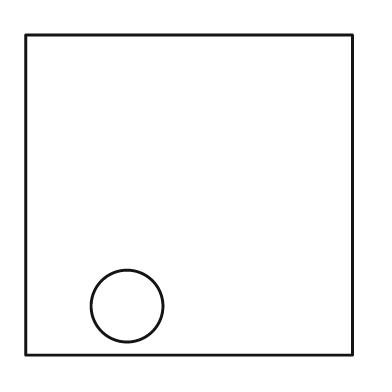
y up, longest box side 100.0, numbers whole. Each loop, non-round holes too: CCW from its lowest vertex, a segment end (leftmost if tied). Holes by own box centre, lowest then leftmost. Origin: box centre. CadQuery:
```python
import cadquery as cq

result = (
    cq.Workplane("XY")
    .moveTo(-50.0, -49.0)
    .lineTo(50.0, -49.0)
    .lineTo(50.0, 49.0)
    .lineTo(-50.0, 49.0)
    .close()
    .moveTo(-19.0, -34.0)
    .circle(11.0)
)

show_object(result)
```